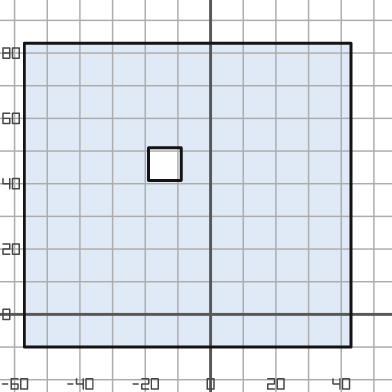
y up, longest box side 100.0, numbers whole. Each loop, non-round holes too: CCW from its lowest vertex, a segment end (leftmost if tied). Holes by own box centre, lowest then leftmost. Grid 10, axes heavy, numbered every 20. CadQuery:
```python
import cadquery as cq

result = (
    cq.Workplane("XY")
    .moveTo(-57.0, -10.0)
    .lineTo(43.0, -10.0)
    .lineTo(43.0, 83.0)
    .lineTo(-57.0, 83.0)
    .close()
    .moveTo(-19.0, 41.0)
    .lineTo(-9.0, 41.0)
    .lineTo(-9.0, 51.0)
    .lineTo(-19.0, 51.0)
    .close()
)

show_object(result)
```